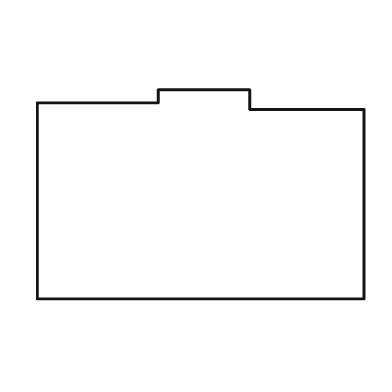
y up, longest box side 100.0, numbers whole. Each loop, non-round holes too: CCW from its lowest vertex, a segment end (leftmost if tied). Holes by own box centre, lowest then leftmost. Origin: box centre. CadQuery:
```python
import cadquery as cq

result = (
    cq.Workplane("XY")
    .moveTo(-50.0, -32.0)
    .lineTo(50.0, -32.0)
    .lineTo(50.0, 26.0)
    .lineTo(15.0, 26.0)
    .lineTo(15.0, 32.0)
    .lineTo(-13.0, 32.0)
    .lineTo(-13.0, 28.0)
    .lineTo(-50.0, 28.0)
    .close()
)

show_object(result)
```